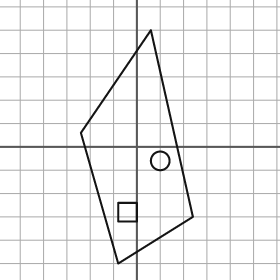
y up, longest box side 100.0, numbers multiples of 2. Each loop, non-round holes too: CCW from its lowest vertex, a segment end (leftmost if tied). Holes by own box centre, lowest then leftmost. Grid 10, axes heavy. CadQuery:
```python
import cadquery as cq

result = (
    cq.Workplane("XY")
    .moveTo(-8.0, -50.0)
    .lineTo(24.0, -30.0)
    .lineTo(6.0, 50.0)
    .lineTo(-24.0, 6.0)
    .close()
    .moveTo(-8.0, -32.0)
    .lineTo(0.0, -32.0)
    .lineTo(0.0, -24.0)
    .lineTo(-8.0, -24.0)
    .close()
    .moveTo(10.0, -6.0)
    .circle(4.0)
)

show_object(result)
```